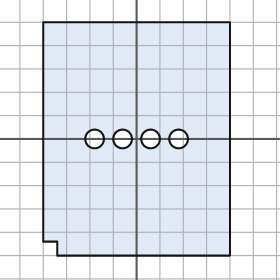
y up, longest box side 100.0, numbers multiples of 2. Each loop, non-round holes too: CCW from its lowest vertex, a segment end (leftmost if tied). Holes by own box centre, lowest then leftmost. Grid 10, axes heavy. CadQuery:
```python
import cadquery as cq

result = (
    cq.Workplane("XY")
    .moveTo(-34.0, -50.0)
    .lineTo(40.0, -50.0)
    .lineTo(40.0, 50.0)
    .lineTo(-40.0, 50.0)
    .lineTo(-40.0, -44.0)
    .lineTo(-34.0, -44.0)
    .close()
    .moveTo(-18.0, 0.0)
    .circle(4.0)
    .moveTo(-6.0, 0.0)
    .circle(4.0)
    .moveTo(6.0, 0.0)
    .circle(4.0)
    .moveTo(18.0, 0.0)
    .circle(4.0)
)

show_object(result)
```